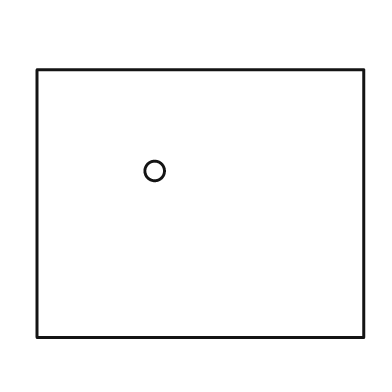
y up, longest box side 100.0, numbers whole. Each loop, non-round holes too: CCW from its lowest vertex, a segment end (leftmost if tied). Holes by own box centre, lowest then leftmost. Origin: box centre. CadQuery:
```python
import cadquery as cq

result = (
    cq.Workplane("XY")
    .moveTo(-50.0, -41.0)
    .lineTo(50.0, -41.0)
    .lineTo(50.0, 41.0)
    .lineTo(-50.0, 41.0)
    .close()
    .moveTo(-14.0, 10.0)
    .circle(3.0)
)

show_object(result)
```